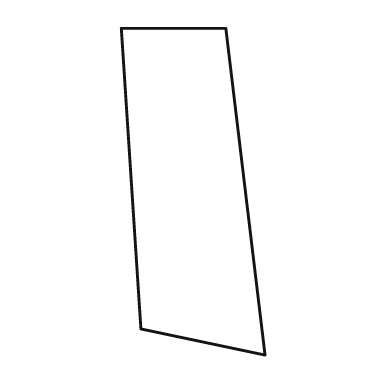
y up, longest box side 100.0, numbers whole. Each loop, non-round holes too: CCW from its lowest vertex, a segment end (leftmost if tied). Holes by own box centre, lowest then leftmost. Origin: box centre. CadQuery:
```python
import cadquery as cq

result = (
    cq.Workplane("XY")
    .moveTo(22.0, -50.0)
    .lineTo(10.0, 50.0)
    .lineTo(-22.0, 50.0)
    .lineTo(-16.0, -42.0)
    .close()
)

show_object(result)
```